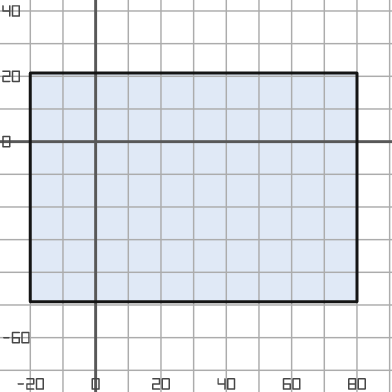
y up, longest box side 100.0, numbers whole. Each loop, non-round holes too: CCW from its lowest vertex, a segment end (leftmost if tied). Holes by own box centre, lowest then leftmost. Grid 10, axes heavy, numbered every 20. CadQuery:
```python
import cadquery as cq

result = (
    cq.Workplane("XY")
    .moveTo(-20.0, -49.0)
    .lineTo(80.0, -49.0)
    .lineTo(80.0, 21.0)
    .lineTo(-20.0, 21.0)
    .close()
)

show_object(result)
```